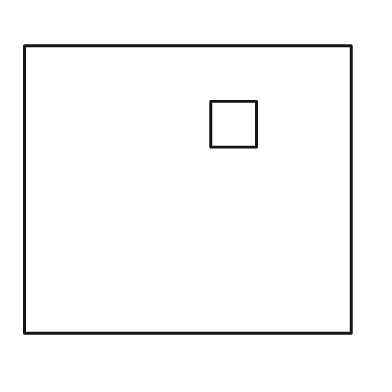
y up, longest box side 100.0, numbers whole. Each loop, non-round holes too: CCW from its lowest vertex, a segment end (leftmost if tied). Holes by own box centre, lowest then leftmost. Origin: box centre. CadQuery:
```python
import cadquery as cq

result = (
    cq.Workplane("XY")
    .moveTo(-50.0, -44.0)
    .lineTo(50.0, -44.0)
    .lineTo(50.0, 44.0)
    .lineTo(-50.0, 44.0)
    .close()
    .moveTo(7.0, 13.0)
    .lineTo(21.0, 13.0)
    .lineTo(21.0, 27.0)
    .lineTo(7.0, 27.0)
    .close()
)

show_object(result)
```